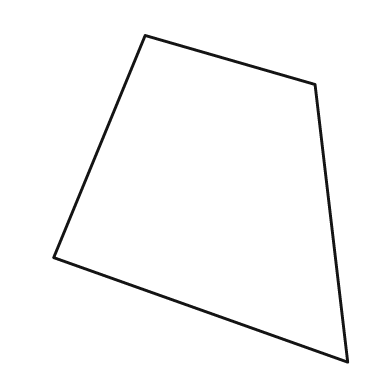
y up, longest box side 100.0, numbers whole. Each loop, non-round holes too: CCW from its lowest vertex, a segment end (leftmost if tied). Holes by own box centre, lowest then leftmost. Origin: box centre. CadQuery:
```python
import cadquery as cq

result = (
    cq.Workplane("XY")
    .moveTo(45.0, -50.0)
    .lineTo(35.0, 35.0)
    .lineTo(-17.0, 50.0)
    .lineTo(-45.0, -18.0)
    .close()
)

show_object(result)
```